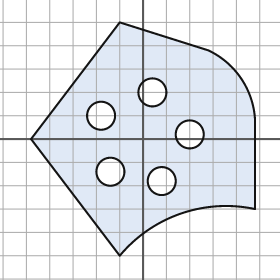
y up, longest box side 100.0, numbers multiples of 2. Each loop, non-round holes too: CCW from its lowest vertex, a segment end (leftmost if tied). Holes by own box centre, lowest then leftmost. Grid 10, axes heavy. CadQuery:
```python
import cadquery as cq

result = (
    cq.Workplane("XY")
    .moveTo(-10.0, -50.0)
    .threePointArc((16.0, -32.0), (48.0, -30.0))
    .lineTo(48.0, 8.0)
    .threePointArc((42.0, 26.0), (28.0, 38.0))
    .lineTo(-10.0, 50.0)
    .lineTo(-48.0, 0.0)
    .close()
    .moveTo(8.0, -18.0)
    .circle(6.0)
    .moveTo(-14.0, -14.0)
    .circle(6.0)
    .moveTo(20.0, 2.0)
    .circle(6.0)
    .moveTo(-18.0, 10.0)
    .circle(6.0)
    .moveTo(4.0, 20.0)
    .circle(6.0)
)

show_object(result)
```